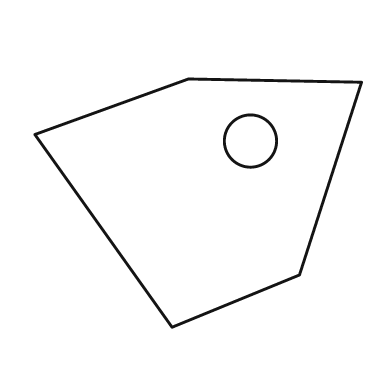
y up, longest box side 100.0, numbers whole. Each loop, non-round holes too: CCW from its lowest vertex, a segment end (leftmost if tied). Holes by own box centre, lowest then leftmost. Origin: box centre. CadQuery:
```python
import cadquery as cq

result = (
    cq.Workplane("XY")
    .moveTo(-8.0, -38.0)
    .lineTo(31.0, -22.0)
    .lineTo(50.0, 37.0)
    .lineTo(-3.0, 38.0)
    .lineTo(-50.0, 21.0)
    .close()
    .moveTo(16.0, 19.0)
    .circle(8.0)
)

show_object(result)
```